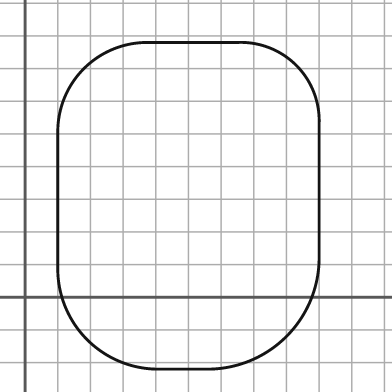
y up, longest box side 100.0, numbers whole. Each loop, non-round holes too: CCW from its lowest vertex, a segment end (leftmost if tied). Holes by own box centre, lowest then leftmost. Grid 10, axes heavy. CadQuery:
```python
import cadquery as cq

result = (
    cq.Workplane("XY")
    .moveTo(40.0, -22.0)
    .lineTo(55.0, -22.0)
    .threePointArc((80.0, -12.0), (90.0, 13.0))
    .lineTo(90.0, 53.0)
    .threePointArc((83.0, 71.0), (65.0, 78.0))
    .lineTo(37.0, 78.0)
    .threePointArc((18.0, 70.0), (10.0, 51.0))
    .lineTo(10.0, 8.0)
    .threePointArc((19.0, -13.0), (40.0, -22.0))
    .close()
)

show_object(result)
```